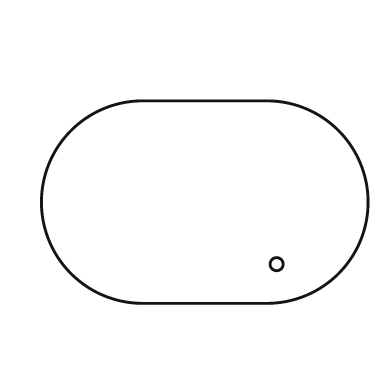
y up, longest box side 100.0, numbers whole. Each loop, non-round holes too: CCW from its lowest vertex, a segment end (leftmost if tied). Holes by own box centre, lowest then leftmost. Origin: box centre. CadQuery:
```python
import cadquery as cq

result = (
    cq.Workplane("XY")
    .moveTo(-19.0, -31.0)
    .lineTo(19.0, -31.0)
    .threePointArc((50.0, 0.0), (19.0, 31.0))
    .lineTo(-19.0, 31.0)
    .threePointArc((-50.0, 0.0), (-19.0, -31.0))
    .close()
    .moveTo(22.0, -19.0)
    .circle(2.0)
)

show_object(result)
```